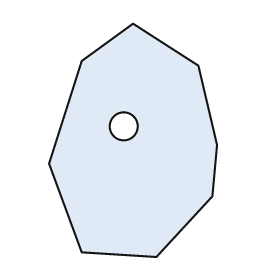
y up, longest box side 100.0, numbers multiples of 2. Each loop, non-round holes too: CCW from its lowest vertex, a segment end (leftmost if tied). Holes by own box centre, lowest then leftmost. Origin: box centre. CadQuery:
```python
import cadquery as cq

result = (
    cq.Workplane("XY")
    .moveTo(10.0, -50.0)
    .lineTo(34.0, -24.0)
    .lineTo(36.0, -2.0)
    .lineTo(28.0, 32.0)
    .lineTo(0.0, 50.0)
    .lineTo(-22.0, 34.0)
    .lineTo(-36.0, -10.0)
    .lineTo(-22.0, -48.0)
    .close()
    .moveTo(-4.0, 6.0)
    .circle(6.0)
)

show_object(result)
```